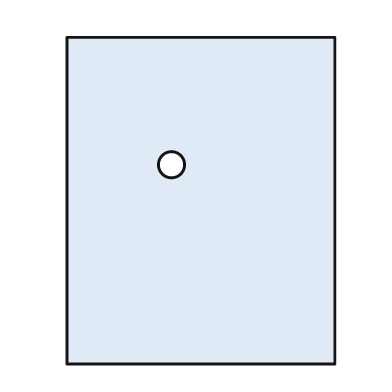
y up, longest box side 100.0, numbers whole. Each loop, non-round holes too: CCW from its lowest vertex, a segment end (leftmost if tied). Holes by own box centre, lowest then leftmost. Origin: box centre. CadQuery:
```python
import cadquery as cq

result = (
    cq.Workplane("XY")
    .moveTo(-41.0, -50.0)
    .lineTo(41.0, -50.0)
    .lineTo(41.0, 50.0)
    .lineTo(-41.0, 50.0)
    .close()
    .moveTo(-9.0, 11.0)
    .circle(4.0)
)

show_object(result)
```